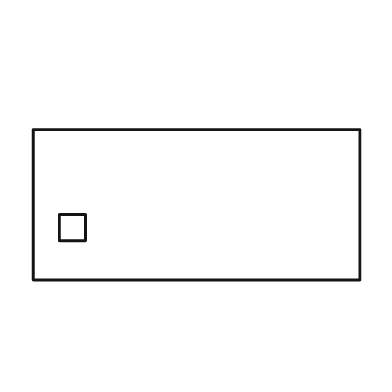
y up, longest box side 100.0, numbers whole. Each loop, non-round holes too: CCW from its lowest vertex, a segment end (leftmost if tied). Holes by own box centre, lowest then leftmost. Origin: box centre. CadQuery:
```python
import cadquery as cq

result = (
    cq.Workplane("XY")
    .moveTo(-50.0, -23.0)
    .lineTo(50.0, -23.0)
    .lineTo(50.0, 23.0)
    .lineTo(-50.0, 23.0)
    .close()
    .moveTo(-42.0, -11.0)
    .lineTo(-34.0, -11.0)
    .lineTo(-34.0, -3.0)
    .lineTo(-42.0, -3.0)
    .close()
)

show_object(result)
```